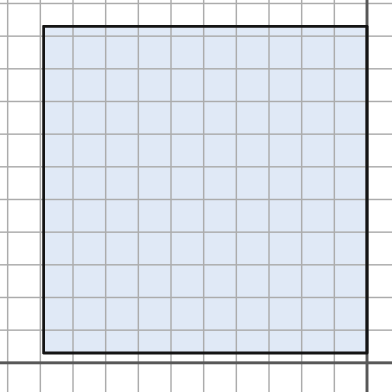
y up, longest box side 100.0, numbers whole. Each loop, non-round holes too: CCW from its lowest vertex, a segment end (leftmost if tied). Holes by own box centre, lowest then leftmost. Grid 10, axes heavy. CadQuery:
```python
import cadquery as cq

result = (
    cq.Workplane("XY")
    .moveTo(-99.0, 3.0)
    .lineTo(0.0, 3.0)
    .lineTo(0.0, 103.0)
    .lineTo(-99.0, 103.0)
    .close()
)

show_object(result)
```